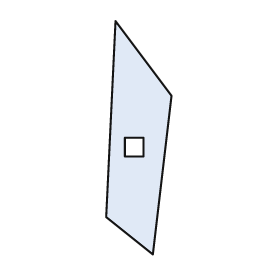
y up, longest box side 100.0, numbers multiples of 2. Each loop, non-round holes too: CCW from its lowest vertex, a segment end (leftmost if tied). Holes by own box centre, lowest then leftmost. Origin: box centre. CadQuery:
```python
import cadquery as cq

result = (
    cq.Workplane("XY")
    .moveTo(6.0, -50.0)
    .lineTo(14.0, 18.0)
    .lineTo(-10.0, 50.0)
    .lineTo(-14.0, -34.0)
    .close()
    .moveTo(-6.0, -8.0)
    .lineTo(2.0, -8.0)
    .lineTo(2.0, 0.0)
    .lineTo(-6.0, 0.0)
    .close()
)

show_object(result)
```